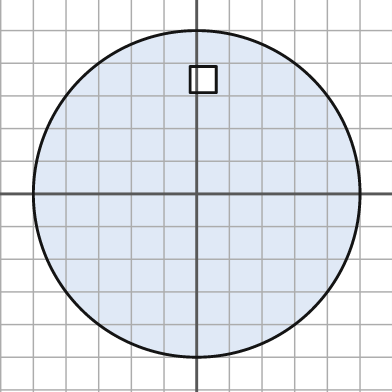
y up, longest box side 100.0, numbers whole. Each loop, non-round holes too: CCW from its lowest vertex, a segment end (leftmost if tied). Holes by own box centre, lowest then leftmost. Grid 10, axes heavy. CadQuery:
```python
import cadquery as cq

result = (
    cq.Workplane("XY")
    .moveTo(0.0, 0.0)
    .circle(50.0)
    .moveTo(-2.0, 31.0)
    .lineTo(6.0, 31.0)
    .lineTo(6.0, 39.0)
    .lineTo(-2.0, 39.0)
    .close()
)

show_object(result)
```